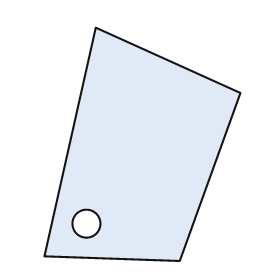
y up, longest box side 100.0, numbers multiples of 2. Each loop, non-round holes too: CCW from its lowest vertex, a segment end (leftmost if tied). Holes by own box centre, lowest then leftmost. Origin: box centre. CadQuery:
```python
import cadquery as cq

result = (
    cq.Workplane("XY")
    .moveTo(16.0, -50.0)
    .lineTo(42.0, 22.0)
    .lineTo(-20.0, 50.0)
    .lineTo(-42.0, -48.0)
    .close()
    .moveTo(-24.0, -34.0)
    .circle(6.0)
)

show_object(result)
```